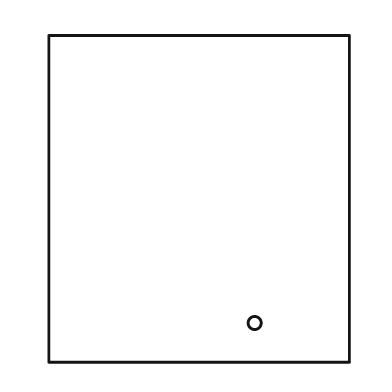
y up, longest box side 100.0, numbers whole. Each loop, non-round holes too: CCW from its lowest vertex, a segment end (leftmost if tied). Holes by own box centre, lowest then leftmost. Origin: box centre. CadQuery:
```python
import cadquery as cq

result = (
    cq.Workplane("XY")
    .moveTo(-46.0, -50.0)
    .lineTo(46.0, -50.0)
    .lineTo(46.0, 50.0)
    .lineTo(-46.0, 50.0)
    .close()
    .moveTo(17.0, -38.0)
    .circle(2.0)
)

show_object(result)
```